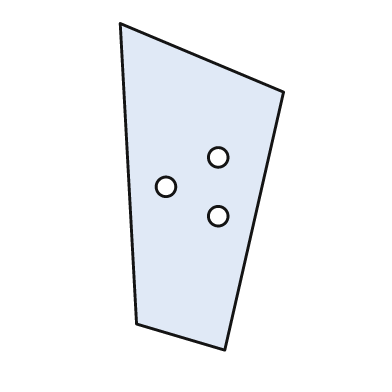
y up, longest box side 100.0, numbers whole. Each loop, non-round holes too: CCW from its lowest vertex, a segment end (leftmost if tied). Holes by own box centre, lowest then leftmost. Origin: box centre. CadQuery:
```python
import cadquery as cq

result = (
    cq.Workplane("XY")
    .moveTo(7.0, -50.0)
    .lineTo(25.0, 29.0)
    .lineTo(-25.0, 50.0)
    .lineTo(-20.0, -42.0)
    .close()
    .moveTo(5.0, -9.0)
    .circle(3.0)
    .moveTo(-11.0, 0.0)
    .circle(3.0)
    .moveTo(5.0, 9.0)
    .circle(3.0)
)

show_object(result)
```